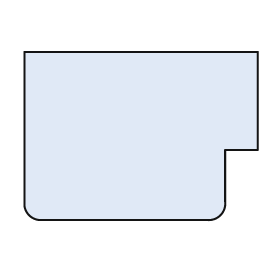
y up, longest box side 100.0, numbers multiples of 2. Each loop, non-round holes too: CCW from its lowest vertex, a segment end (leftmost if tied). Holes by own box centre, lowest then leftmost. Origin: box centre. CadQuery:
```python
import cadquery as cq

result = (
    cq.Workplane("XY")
    .moveTo(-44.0, -36.0)
    .lineTo(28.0, -36.0)
    .threePointArc((34.0, -34.0), (36.0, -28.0))
    .lineTo(36.0, -6.0)
    .lineTo(50.0, -6.0)
    .lineTo(50.0, 36.0)
    .lineTo(-50.0, 36.0)
    .lineTo(-50.0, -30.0)
    .threePointArc((-48.0, -34.0), (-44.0, -36.0))
    .close()
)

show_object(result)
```